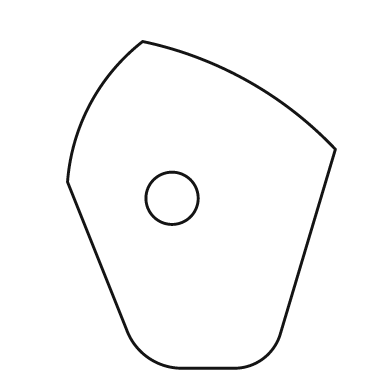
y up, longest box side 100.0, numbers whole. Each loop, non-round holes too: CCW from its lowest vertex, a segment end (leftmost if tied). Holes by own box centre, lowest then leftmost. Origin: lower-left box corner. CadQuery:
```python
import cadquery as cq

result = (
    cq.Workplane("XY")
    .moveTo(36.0, 0.0)
    .lineTo(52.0, 0.0)
    .threePointArc((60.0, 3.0), (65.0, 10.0))
    .lineTo(82.0, 67.0)
    .threePointArc((55.0, 88.0), (23.0, 100.0))
    .threePointArc((7.0, 81.0), (0.0, 57.0))
    .lineTo(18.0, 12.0)
    .threePointArc((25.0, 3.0), (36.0, 0.0))
    .close()
    .moveTo(32.0, 52.0)
    .circle(8.0)
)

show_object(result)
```